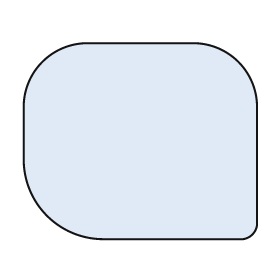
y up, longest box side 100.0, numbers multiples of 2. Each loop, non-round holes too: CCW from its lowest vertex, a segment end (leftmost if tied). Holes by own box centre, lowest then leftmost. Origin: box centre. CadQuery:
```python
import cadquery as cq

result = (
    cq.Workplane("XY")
    .moveTo(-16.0, -42.0)
    .lineTo(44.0, -42.0)
    .threePointArc((48.0, -40.0), (50.0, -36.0))
    .lineTo(50.0, 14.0)
    .threePointArc((42.0, 34.0), (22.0, 42.0))
    .lineTo(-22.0, 42.0)
    .threePointArc((-42.0, 34.0), (-50.0, 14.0))
    .lineTo(-50.0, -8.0)
    .threePointArc((-40.0, -32.0), (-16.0, -42.0))
    .close()
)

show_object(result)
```